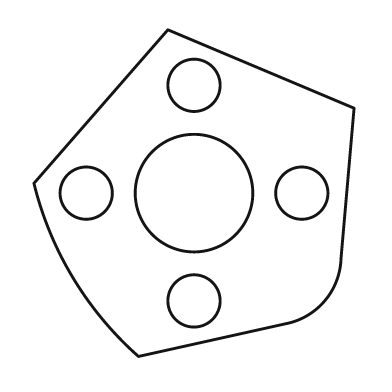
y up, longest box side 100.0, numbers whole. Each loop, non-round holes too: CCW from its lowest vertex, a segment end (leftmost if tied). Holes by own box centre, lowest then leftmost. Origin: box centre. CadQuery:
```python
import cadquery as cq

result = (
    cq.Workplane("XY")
    .moveTo(-17.0, -50.0)
    .lineTo(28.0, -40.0)
    .threePointArc((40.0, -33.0), (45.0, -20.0))
    .lineTo(49.0, 26.0)
    .lineTo(-8.0, 50.0)
    .lineTo(-49.0, 3.0)
    .threePointArc((-37.0, -26.0), (-17.0, -50.0))
    .close()
    .moveTo(0.0, -33.0)
    .circle(8.0)
    .moveTo(-33.0, 0.0)
    .circle(8.0)
    .moveTo(0.0, 0.0)
    .circle(18.0)
    .moveTo(33.0, 0.0)
    .circle(8.0)
    .moveTo(0.0, 33.0)
    .circle(8.0)
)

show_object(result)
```